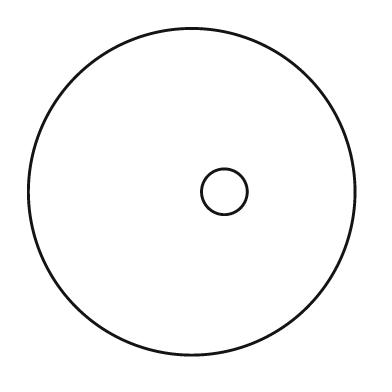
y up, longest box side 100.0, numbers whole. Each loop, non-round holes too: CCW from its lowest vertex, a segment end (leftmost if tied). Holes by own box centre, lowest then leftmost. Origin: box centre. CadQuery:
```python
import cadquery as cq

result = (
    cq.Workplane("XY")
    .moveTo(0.0, 0.0)
    .circle(50.0)
    .moveTo(10.0, 0.0)
    .circle(7.0)
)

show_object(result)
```